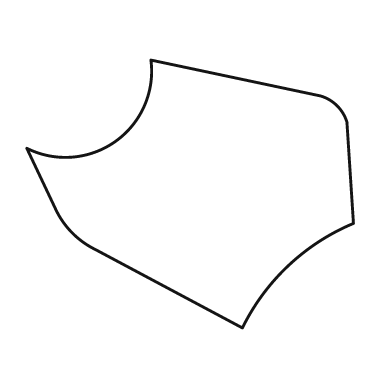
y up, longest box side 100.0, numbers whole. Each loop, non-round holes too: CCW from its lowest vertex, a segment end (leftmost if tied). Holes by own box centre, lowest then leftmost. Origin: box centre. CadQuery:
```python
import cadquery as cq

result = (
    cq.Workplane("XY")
    .moveTo(16.0, -41.0)
    .threePointArc((30.0, -22.0), (50.0, -9.0))
    .lineTo(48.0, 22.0)
    .threePointArc((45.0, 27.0), (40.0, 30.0))
    .lineTo(-12.0, 41.0)
    .threePointArc((-23.0, 16.0), (-50.0, 14.0))
    .lineTo(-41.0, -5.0)
    .threePointArc((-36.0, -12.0), (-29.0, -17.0))
    .close()
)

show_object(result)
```